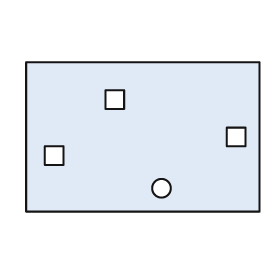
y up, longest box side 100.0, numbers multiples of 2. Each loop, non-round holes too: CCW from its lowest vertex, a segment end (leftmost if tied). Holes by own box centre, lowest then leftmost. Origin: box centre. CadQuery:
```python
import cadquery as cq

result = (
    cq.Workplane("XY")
    .moveTo(-50.0, -32.0)
    .lineTo(50.0, -32.0)
    .lineTo(50.0, 32.0)
    .lineTo(-50.0, 32.0)
    .close()
    .moveTo(8.0, -22.0)
    .circle(4.0)
    .moveTo(-42.0, -12.0)
    .lineTo(-34.0, -12.0)
    .lineTo(-34.0, -4.0)
    .lineTo(-42.0, -4.0)
    .close()
    .moveTo(36.0, -4.0)
    .lineTo(44.0, -4.0)
    .lineTo(44.0, 4.0)
    .lineTo(36.0, 4.0)
    .close()
    .moveTo(-16.0, 12.0)
    .lineTo(-8.0, 12.0)
    .lineTo(-8.0, 20.0)
    .lineTo(-16.0, 20.0)
    .close()
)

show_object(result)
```